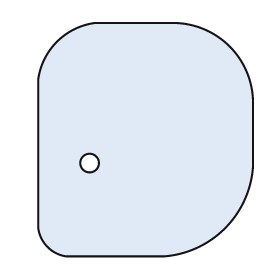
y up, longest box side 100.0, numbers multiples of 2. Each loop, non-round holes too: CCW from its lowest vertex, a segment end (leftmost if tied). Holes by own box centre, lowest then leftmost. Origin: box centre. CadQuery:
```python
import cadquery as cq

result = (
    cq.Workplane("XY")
    .moveTo(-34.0, -50.0)
    .lineTo(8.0, -50.0)
    .threePointArc((34.0, -38.0), (46.0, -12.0))
    .lineTo(46.0, 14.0)
    .threePointArc((36.0, 40.0), (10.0, 50.0))
    .lineTo(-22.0, 50.0)
    .threePointArc((-38.0, 42.0), (-46.0, 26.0))
    .lineTo(-46.0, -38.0)
    .threePointArc((-42.0, -46.0), (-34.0, -50.0))
    .close()
    .moveTo(-24.0, -10.0)
    .circle(4.0)
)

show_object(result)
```